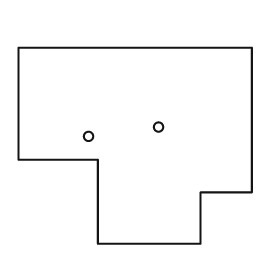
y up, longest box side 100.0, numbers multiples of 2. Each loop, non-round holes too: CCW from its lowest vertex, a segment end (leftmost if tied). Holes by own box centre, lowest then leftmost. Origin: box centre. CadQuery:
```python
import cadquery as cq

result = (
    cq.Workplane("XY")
    .moveTo(-16.0, -42.0)
    .lineTo(28.0, -42.0)
    .lineTo(28.0, -20.0)
    .lineTo(50.0, -20.0)
    .lineTo(50.0, 42.0)
    .lineTo(-50.0, 42.0)
    .lineTo(-50.0, -6.0)
    .lineTo(-16.0, -6.0)
    .close()
    .moveTo(-20.0, 4.0)
    .circle(2.0)
    .moveTo(10.0, 8.0)
    .circle(2.0)
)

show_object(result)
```